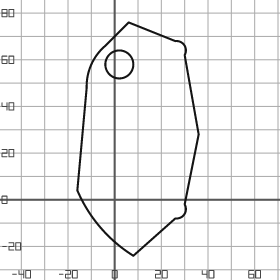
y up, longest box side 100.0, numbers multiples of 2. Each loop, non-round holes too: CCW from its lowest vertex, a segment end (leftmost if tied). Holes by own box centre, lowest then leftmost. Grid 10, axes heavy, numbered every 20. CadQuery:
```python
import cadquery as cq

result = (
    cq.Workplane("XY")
    .moveTo(8.0, -24.0)
    .lineTo(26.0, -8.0)
    .threePointArc((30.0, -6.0), (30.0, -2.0))
    .lineTo(36.0, 28.0)
    .lineTo(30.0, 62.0)
    .threePointArc((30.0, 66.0), (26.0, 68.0))
    .lineTo(6.0, 76.0)
    .lineTo(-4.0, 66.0)
    .threePointArc((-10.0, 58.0), (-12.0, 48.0))
    .lineTo(-16.0, 4.0)
    .threePointArc((-6.0, -12.0), (8.0, -24.0))
    .close()
    .moveTo(2.0, 58.0)
    .circle(6.0)
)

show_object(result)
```